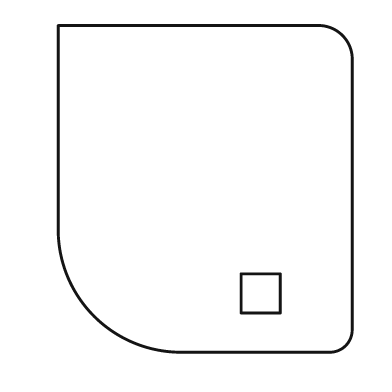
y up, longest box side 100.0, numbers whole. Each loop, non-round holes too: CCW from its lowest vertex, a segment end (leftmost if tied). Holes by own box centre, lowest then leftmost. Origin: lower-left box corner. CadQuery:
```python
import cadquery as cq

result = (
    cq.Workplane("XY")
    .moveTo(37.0, 0.0)
    .lineTo(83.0, 0.0)
    .threePointArc((88.0, 2.0), (90.0, 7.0))
    .lineTo(90.0, 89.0)
    .threePointArc((87.0, 97.0), (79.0, 100.0))
    .lineTo(0.0, 100.0)
    .lineTo(0.0, 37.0)
    .threePointArc((11.0, 11.0), (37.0, 0.0))
    .close()
    .moveTo(56.0, 12.0)
    .lineTo(68.0, 12.0)
    .lineTo(68.0, 24.0)
    .lineTo(56.0, 24.0)
    .close()
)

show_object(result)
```